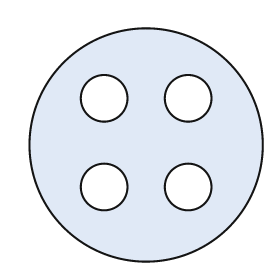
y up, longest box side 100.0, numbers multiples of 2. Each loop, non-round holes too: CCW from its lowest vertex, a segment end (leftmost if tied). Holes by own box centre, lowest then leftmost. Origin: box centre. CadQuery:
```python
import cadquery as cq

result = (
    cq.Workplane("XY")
    .moveTo(0.0, 0.0)
    .circle(50.0)
    .moveTo(-18.0, -18.0)
    .circle(10.0)
    .moveTo(18.0, -18.0)
    .circle(10.0)
    .moveTo(-18.0, 20.0)
    .circle(10.0)
    .moveTo(18.0, 20.0)
    .circle(10.0)
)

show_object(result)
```